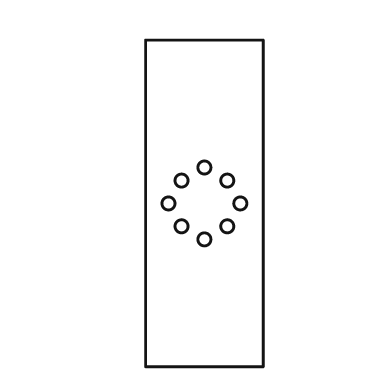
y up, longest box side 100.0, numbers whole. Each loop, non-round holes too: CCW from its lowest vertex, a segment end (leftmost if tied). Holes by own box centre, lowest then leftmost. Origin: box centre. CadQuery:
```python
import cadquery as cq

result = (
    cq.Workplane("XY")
    .moveTo(-18.0, -50.0)
    .lineTo(18.0, -50.0)
    .lineTo(18.0, 50.0)
    .lineTo(-18.0, 50.0)
    .close()
    .moveTo(0.0, -11.0)
    .circle(2.0)
    .moveTo(-7.0, -7.0)
    .circle(2.0)
    .moveTo(7.0, -7.0)
    .circle(2.0)
    .moveTo(-11.0, 0.0)
    .circle(2.0)
    .moveTo(11.0, 0.0)
    .circle(2.0)
    .moveTo(-7.0, 7.0)
    .circle(2.0)
    .moveTo(7.0, 7.0)
    .circle(2.0)
    .moveTo(0.0, 11.0)
    .circle(2.0)
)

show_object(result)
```